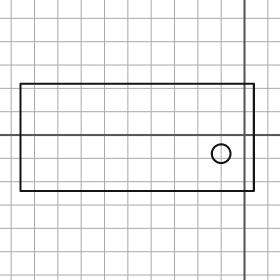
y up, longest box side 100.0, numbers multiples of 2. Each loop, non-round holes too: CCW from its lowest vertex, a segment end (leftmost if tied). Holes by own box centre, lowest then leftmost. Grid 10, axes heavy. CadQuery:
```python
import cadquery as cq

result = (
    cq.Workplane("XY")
    .moveTo(-96.0, -24.0)
    .lineTo(4.0, -24.0)
    .lineTo(4.0, 22.0)
    .lineTo(-96.0, 22.0)
    .close()
    .moveTo(-10.0, -8.0)
    .circle(4.0)
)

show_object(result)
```